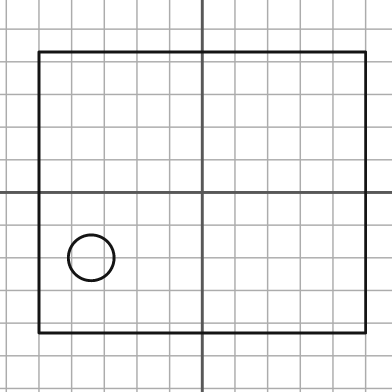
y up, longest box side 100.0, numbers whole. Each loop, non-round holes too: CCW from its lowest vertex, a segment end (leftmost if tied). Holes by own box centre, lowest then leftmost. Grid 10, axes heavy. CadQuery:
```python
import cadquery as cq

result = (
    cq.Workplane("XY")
    .moveTo(-50.0, -43.0)
    .lineTo(50.0, -43.0)
    .lineTo(50.0, 43.0)
    .lineTo(-50.0, 43.0)
    .close()
    .moveTo(-34.0, -20.0)
    .circle(7.0)
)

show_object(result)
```